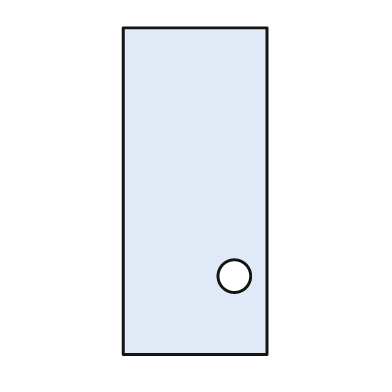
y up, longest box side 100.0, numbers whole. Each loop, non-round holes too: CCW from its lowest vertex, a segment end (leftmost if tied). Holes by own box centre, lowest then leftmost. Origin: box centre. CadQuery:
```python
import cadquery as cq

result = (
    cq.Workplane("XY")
    .moveTo(-22.0, -50.0)
    .lineTo(22.0, -50.0)
    .lineTo(22.0, 50.0)
    .lineTo(-22.0, 50.0)
    .close()
    .moveTo(12.0, -26.0)
    .circle(5.0)
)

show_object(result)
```